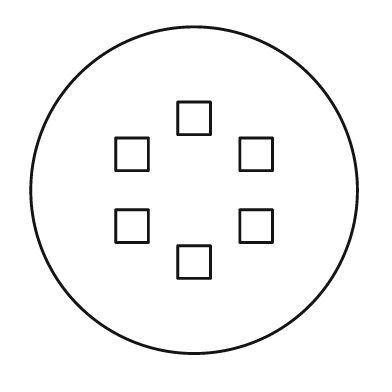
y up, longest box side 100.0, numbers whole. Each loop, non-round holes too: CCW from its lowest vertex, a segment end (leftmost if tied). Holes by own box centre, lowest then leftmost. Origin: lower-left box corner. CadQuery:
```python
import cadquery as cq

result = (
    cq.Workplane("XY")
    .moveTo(50.0, 50.0)
    .circle(50.0)
    .moveTo(45.0, 23.0)
    .lineTo(55.0, 23.0)
    .lineTo(55.0, 33.0)
    .lineTo(45.0, 33.0)
    .close()
    .moveTo(26.0, 34.0)
    .lineTo(36.0, 34.0)
    .lineTo(36.0, 44.0)
    .lineTo(26.0, 44.0)
    .close()
    .moveTo(64.0, 34.0)
    .lineTo(74.0, 34.0)
    .lineTo(74.0, 44.0)
    .lineTo(64.0, 44.0)
    .close()
    .moveTo(26.0, 56.0)
    .lineTo(36.0, 56.0)
    .lineTo(36.0, 66.0)
    .lineTo(26.0, 66.0)
    .close()
    .moveTo(64.0, 56.0)
    .lineTo(74.0, 56.0)
    .lineTo(74.0, 66.0)
    .lineTo(64.0, 66.0)
    .close()
    .moveTo(45.0, 67.0)
    .lineTo(55.0, 67.0)
    .lineTo(55.0, 77.0)
    .lineTo(45.0, 77.0)
    .close()
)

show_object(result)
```